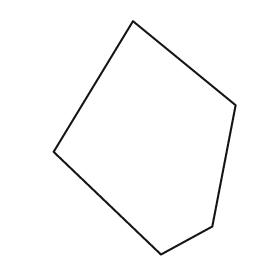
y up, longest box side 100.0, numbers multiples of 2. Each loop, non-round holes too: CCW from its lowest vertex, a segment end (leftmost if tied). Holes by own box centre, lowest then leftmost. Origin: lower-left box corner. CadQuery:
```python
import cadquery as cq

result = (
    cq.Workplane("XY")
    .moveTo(46.0, 0.0)
    .lineTo(68.0, 12.0)
    .lineTo(78.0, 64.0)
    .lineTo(34.0, 100.0)
    .lineTo(0.0, 44.0)
    .close()
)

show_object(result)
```